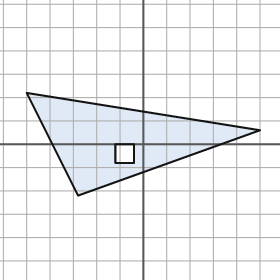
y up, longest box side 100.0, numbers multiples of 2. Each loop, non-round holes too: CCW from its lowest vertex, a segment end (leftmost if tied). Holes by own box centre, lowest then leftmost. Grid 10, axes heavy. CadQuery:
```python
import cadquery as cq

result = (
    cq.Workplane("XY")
    .moveTo(-28.0, -22.0)
    .lineTo(50.0, 6.0)
    .lineTo(-50.0, 22.0)
    .close()
    .moveTo(-12.0, -8.0)
    .lineTo(-4.0, -8.0)
    .lineTo(-4.0, 0.0)
    .lineTo(-12.0, 0.0)
    .close()
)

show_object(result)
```